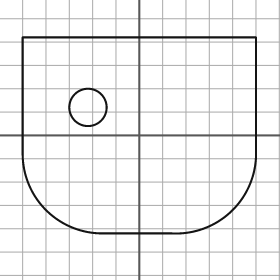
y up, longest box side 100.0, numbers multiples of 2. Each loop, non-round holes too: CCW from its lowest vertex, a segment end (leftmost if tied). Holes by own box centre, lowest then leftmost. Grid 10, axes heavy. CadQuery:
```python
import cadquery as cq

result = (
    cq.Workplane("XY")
    .moveTo(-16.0, -42.0)
    .lineTo(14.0, -42.0)
    .threePointArc((40.0, -32.0), (50.0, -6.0))
    .lineTo(50.0, 42.0)
    .lineTo(-50.0, 42.0)
    .lineTo(-50.0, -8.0)
    .threePointArc((-40.0, -32.0), (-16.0, -42.0))
    .close()
    .moveTo(-22.0, 12.0)
    .circle(8.0)
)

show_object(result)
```